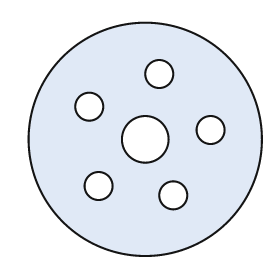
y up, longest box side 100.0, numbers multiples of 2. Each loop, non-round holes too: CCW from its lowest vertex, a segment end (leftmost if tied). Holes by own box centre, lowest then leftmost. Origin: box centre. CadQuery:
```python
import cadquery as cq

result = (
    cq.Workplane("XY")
    .moveTo(0.0, 0.0)
    .circle(50.0)
    .moveTo(12.0, -24.0)
    .circle(6.0)
    .moveTo(-20.0, -20.0)
    .circle(6.0)
    .moveTo(0.0, 0.0)
    .circle(10.0)
    .moveTo(28.0, 4.0)
    .circle(6.0)
    .moveTo(-24.0, 14.0)
    .circle(6.0)
    .moveTo(6.0, 28.0)
    .circle(6.0)
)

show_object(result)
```